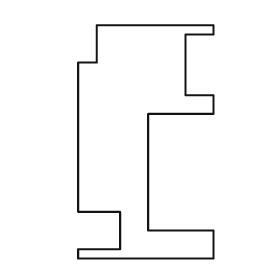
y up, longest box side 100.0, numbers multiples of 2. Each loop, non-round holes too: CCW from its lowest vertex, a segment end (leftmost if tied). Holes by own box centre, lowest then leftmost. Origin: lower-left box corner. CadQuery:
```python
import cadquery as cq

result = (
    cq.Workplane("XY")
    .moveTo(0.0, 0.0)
    .lineTo(58.0, 0.0)
    .lineTo(58.0, 12.0)
    .lineTo(30.0, 12.0)
    .lineTo(30.0, 62.0)
    .lineTo(58.0, 62.0)
    .lineTo(58.0, 70.0)
    .lineTo(46.0, 70.0)
    .lineTo(46.0, 96.0)
    .lineTo(58.0, 96.0)
    .lineTo(58.0, 100.0)
    .lineTo(8.0, 100.0)
    .lineTo(8.0, 84.0)
    .lineTo(0.0, 84.0)
    .lineTo(0.0, 20.0)
    .lineTo(18.0, 20.0)
    .lineTo(18.0, 4.0)
    .lineTo(0.0, 4.0)
    .close()
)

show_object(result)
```